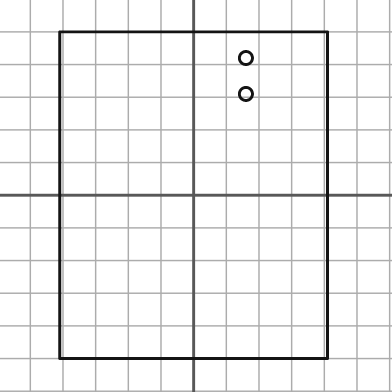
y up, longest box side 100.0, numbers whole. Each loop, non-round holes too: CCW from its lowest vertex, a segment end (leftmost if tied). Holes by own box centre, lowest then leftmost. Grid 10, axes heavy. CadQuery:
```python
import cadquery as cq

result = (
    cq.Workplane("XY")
    .moveTo(-41.0, -50.0)
    .lineTo(41.0, -50.0)
    .lineTo(41.0, 50.0)
    .lineTo(-41.0, 50.0)
    .close()
    .moveTo(16.0, 31.0)
    .circle(2.0)
    .moveTo(16.0, 42.0)
    .circle(2.0)
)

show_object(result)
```